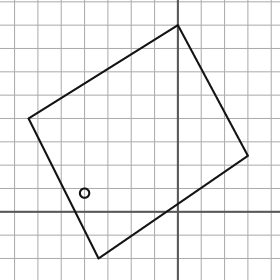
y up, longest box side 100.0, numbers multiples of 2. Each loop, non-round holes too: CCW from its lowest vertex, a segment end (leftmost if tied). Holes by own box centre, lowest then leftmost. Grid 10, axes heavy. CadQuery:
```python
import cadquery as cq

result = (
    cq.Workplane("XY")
    .moveTo(-34.0, -20.0)
    .lineTo(30.0, 24.0)
    .lineTo(0.0, 80.0)
    .lineTo(-64.0, 40.0)
    .close()
    .moveTo(-40.0, 8.0)
    .circle(2.0)
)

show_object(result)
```